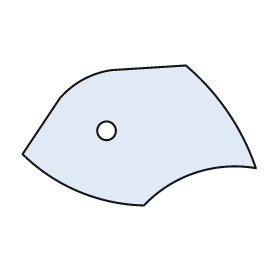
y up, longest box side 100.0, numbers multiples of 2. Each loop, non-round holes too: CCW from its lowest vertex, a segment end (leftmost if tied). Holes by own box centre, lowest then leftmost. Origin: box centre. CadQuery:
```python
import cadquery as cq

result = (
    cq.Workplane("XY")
    .moveTo(2.0, -30.0)
    .threePointArc((24.0, -16.0), (50.0, -14.0))
    .threePointArc((38.0, 10.0), (20.0, 30.0))
    .lineTo(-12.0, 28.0)
    .threePointArc((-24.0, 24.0), (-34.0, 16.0))
    .lineTo(-50.0, -8.0)
    .threePointArc((-26.0, -24.0), (2.0, -30.0))
    .close()
    .moveTo(-14.0, 2.0)
    .circle(4.0)
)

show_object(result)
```